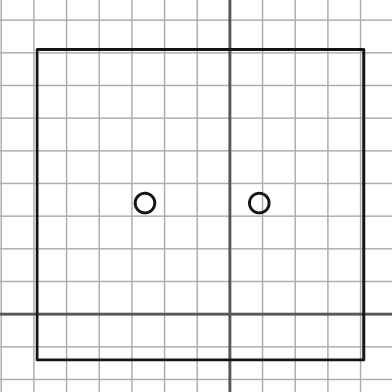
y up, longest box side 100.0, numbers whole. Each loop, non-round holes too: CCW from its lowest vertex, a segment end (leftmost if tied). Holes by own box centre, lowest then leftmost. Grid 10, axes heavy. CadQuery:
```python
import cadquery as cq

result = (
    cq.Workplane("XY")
    .moveTo(-59.0, -14.0)
    .lineTo(41.0, -14.0)
    .lineTo(41.0, 81.0)
    .lineTo(-59.0, 81.0)
    .close()
    .moveTo(-26.0, 34.0)
    .circle(3.0)
    .moveTo(9.0, 34.0)
    .circle(3.0)
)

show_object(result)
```